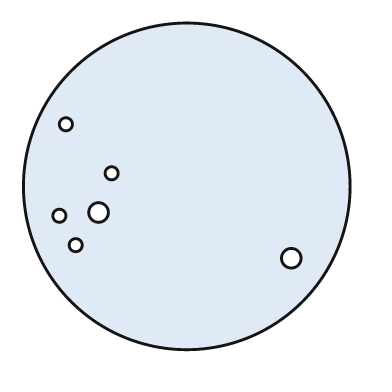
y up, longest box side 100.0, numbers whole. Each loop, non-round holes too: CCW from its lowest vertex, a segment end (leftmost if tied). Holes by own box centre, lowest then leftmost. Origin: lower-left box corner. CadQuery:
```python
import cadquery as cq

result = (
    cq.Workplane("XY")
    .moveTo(50.0, 50.0)
    .circle(50.0)
    .moveTo(82.0, 28.0)
    .circle(3.0)
    .moveTo(16.0, 32.0)
    .circle(2.0)
    .moveTo(11.0, 41.0)
    .circle(2.0)
    .moveTo(23.0, 42.0)
    .circle(3.0)
    .moveTo(27.0, 54.0)
    .circle(2.0)
    .moveTo(13.0, 69.0)
    .circle(2.0)
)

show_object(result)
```